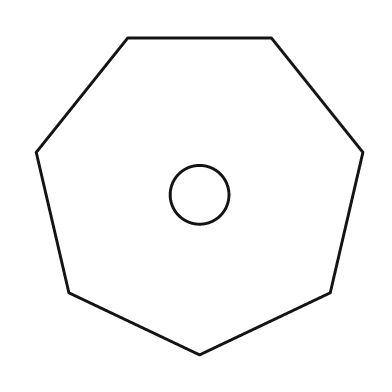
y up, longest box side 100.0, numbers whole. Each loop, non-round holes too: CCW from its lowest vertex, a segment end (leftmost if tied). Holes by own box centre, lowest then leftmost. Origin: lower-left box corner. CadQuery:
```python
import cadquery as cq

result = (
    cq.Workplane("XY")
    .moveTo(50.0, 0.0)
    .lineTo(90.0, 19.0)
    .lineTo(100.0, 62.0)
    .lineTo(72.0, 97.0)
    .lineTo(28.0, 97.0)
    .lineTo(0.0, 62.0)
    .lineTo(10.0, 19.0)
    .close()
    .moveTo(50.0, 49.0)
    .circle(9.0)
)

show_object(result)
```